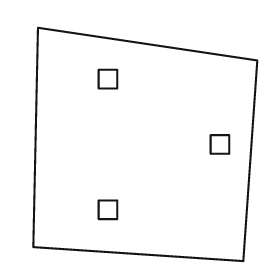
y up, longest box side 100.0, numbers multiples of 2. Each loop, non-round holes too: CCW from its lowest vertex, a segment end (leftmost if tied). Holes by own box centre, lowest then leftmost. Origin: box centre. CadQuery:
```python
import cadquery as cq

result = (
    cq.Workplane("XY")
    .moveTo(42.0, -50.0)
    .lineTo(48.0, 36.0)
    .lineTo(-46.0, 50.0)
    .lineTo(-48.0, -44.0)
    .close()
    .moveTo(-20.0, -32.0)
    .lineTo(-12.0, -32.0)
    .lineTo(-12.0, -24.0)
    .lineTo(-20.0, -24.0)
    .close()
    .moveTo(28.0, -4.0)
    .lineTo(36.0, -4.0)
    .lineTo(36.0, 4.0)
    .lineTo(28.0, 4.0)
    .close()
    .moveTo(-20.0, 24.0)
    .lineTo(-12.0, 24.0)
    .lineTo(-12.0, 32.0)
    .lineTo(-20.0, 32.0)
    .close()
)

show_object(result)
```